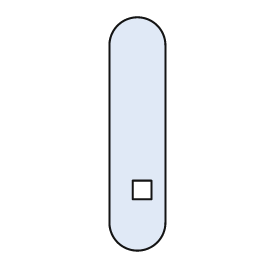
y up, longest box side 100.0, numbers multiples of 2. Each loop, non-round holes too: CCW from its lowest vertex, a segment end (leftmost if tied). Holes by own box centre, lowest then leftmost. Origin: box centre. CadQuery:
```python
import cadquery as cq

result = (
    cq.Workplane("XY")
    .moveTo(-12.0, -38.0)
    .threePointArc((0.0, -50.0), (12.0, -38.0))
    .lineTo(12.0, 38.0)
    .threePointArc((0.0, 50.0), (-12.0, 38.0))
    .close()
    .moveTo(-2.0, -28.0)
    .lineTo(6.0, -28.0)
    .lineTo(6.0, -20.0)
    .lineTo(-2.0, -20.0)
    .close()
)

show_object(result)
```